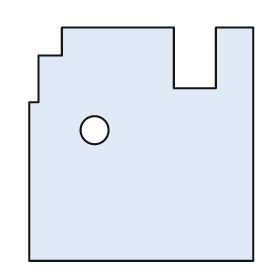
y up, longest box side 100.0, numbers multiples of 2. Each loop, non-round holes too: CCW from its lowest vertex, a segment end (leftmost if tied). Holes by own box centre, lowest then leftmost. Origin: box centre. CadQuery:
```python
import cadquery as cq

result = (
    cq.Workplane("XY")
    .moveTo(-48.0, -50.0)
    .lineTo(48.0, -50.0)
    .lineTo(48.0, 50.0)
    .lineTo(32.0, 50.0)
    .lineTo(32.0, 24.0)
    .lineTo(14.0, 24.0)
    .lineTo(14.0, 50.0)
    .lineTo(-34.0, 50.0)
    .lineTo(-34.0, 38.0)
    .lineTo(-44.0, 38.0)
    .lineTo(-44.0, 18.0)
    .lineTo(-48.0, 18.0)
    .close()
    .moveTo(-20.0, 6.0)
    .circle(6.0)
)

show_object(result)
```